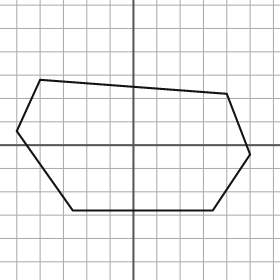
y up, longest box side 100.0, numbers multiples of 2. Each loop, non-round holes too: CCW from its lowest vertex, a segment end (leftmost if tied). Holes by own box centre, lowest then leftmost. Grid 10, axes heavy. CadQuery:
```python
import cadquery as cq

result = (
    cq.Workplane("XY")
    .moveTo(-26.0, -28.0)
    .lineTo(34.0, -28.0)
    .lineTo(50.0, -4.0)
    .lineTo(40.0, 22.0)
    .lineTo(-40.0, 28.0)
    .lineTo(-50.0, 6.0)
    .close()
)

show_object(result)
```